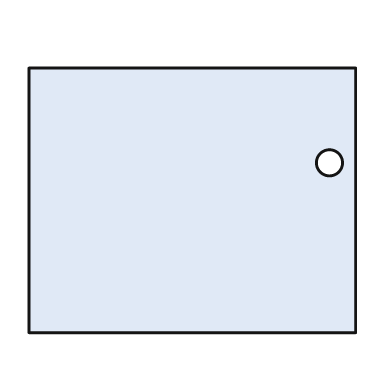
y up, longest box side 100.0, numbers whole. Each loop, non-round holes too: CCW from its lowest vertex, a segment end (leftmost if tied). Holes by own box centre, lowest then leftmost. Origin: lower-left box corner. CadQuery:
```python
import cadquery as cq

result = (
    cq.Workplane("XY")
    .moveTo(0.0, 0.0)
    .lineTo(100.0, 0.0)
    .lineTo(100.0, 81.0)
    .lineTo(0.0, 81.0)
    .close()
    .moveTo(92.0, 52.0)
    .circle(4.0)
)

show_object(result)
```